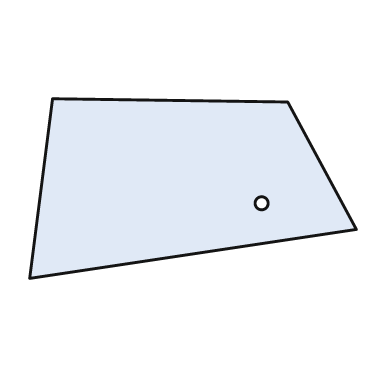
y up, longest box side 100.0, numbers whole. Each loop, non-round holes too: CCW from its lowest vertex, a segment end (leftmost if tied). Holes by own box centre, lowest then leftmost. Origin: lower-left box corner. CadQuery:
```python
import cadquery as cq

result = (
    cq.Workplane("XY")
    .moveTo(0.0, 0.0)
    .lineTo(100.0, 15.0)
    .lineTo(79.0, 54.0)
    .lineTo(7.0, 55.0)
    .close()
    .moveTo(71.0, 23.0)
    .circle(2.0)
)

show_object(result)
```